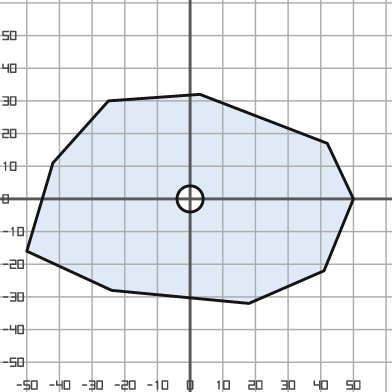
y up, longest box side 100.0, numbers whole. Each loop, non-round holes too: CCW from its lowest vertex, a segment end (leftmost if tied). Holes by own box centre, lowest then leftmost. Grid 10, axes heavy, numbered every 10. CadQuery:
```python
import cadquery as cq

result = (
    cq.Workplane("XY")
    .moveTo(18.0, -32.0)
    .lineTo(41.0, -22.0)
    .lineTo(50.0, 0.0)
    .lineTo(42.0, 17.0)
    .lineTo(3.0, 32.0)
    .lineTo(-25.0, 30.0)
    .lineTo(-42.0, 11.0)
    .lineTo(-50.0, -16.0)
    .lineTo(-24.0, -28.0)
    .close()
    .moveTo(0.0, 0.0)
    .circle(4.0)
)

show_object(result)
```